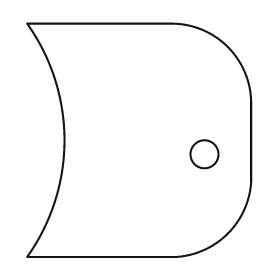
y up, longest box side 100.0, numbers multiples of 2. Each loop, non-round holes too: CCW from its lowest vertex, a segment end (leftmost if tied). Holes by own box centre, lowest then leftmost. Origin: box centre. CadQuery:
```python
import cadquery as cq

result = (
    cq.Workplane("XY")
    .moveTo(-48.0, -50.0)
    .lineTo(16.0, -50.0)
    .threePointArc((38.0, -40.0), (48.0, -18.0))
    .lineTo(48.0, 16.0)
    .threePointArc((38.0, 40.0), (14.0, 50.0))
    .lineTo(-48.0, 50.0)
    .threePointArc((-32.0, 0.0), (-48.0, -50.0))
    .close()
    .moveTo(28.0, -6.0)
    .circle(6.0)
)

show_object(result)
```